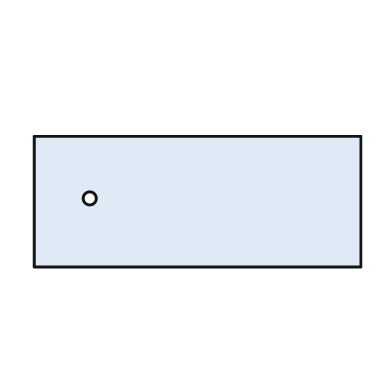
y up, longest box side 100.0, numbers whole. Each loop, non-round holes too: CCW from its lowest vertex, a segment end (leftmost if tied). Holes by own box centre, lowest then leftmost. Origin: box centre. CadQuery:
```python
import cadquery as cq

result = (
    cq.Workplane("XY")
    .moveTo(-50.0, -20.0)
    .lineTo(50.0, -20.0)
    .lineTo(50.0, 20.0)
    .lineTo(-50.0, 20.0)
    .close()
    .moveTo(-33.0, 1.0)
    .circle(2.0)
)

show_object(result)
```